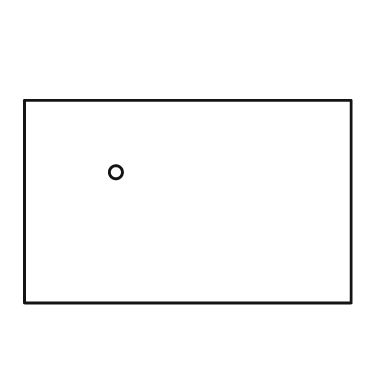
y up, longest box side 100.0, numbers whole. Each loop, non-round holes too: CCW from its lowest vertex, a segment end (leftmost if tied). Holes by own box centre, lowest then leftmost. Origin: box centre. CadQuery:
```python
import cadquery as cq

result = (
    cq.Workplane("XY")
    .moveTo(-50.0, -31.0)
    .lineTo(50.0, -31.0)
    .lineTo(50.0, 31.0)
    .lineTo(-50.0, 31.0)
    .close()
    .moveTo(-22.0, 9.0)
    .circle(2.0)
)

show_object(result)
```